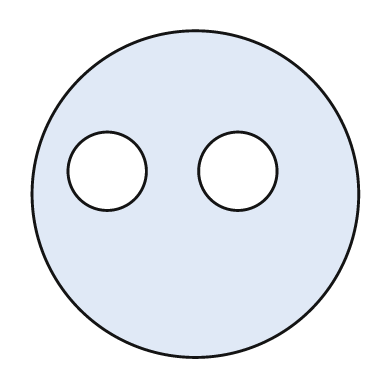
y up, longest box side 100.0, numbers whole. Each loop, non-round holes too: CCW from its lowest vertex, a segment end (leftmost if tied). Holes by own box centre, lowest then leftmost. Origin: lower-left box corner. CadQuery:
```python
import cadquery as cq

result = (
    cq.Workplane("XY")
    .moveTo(50.0, 50.0)
    .circle(50.0)
    .moveTo(23.0, 57.0)
    .circle(12.0)
    .moveTo(63.0, 57.0)
    .circle(12.0)
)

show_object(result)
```